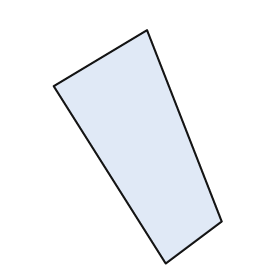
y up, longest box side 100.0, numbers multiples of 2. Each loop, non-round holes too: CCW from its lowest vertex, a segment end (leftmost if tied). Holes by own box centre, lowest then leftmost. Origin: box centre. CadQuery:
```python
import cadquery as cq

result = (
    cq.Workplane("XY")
    .moveTo(12.0, -50.0)
    .lineTo(36.0, -32.0)
    .lineTo(4.0, 50.0)
    .lineTo(-36.0, 26.0)
    .close()
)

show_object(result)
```